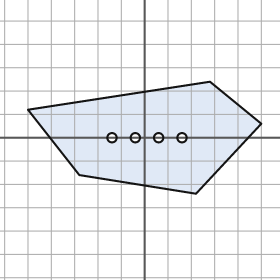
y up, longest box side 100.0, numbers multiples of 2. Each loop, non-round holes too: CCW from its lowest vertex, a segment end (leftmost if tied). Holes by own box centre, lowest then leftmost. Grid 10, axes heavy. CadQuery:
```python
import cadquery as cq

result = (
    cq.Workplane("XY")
    .moveTo(22.0, -24.0)
    .lineTo(50.0, 6.0)
    .lineTo(28.0, 24.0)
    .lineTo(-50.0, 12.0)
    .lineTo(-28.0, -16.0)
    .close()
    .moveTo(-14.0, 0.0)
    .circle(2.0)
    .moveTo(-4.0, 0.0)
    .circle(2.0)
    .moveTo(6.0, 0.0)
    .circle(2.0)
    .moveTo(16.0, 0.0)
    .circle(2.0)
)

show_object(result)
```